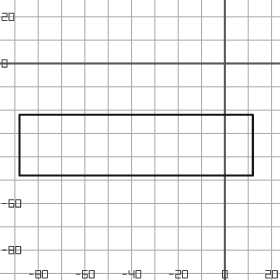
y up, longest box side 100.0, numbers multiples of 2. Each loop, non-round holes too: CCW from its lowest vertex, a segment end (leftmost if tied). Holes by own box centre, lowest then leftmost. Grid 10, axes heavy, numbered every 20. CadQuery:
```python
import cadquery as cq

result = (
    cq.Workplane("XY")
    .moveTo(-88.0, -48.0)
    .lineTo(12.0, -48.0)
    .lineTo(12.0, -22.0)
    .lineTo(-88.0, -22.0)
    .close()
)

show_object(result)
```